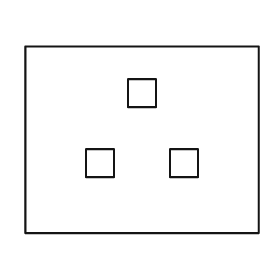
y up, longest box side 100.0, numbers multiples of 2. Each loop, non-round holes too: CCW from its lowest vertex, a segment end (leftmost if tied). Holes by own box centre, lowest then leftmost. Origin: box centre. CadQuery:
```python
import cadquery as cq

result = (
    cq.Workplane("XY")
    .moveTo(-50.0, -40.0)
    .lineTo(50.0, -40.0)
    .lineTo(50.0, 40.0)
    .lineTo(-50.0, 40.0)
    .close()
    .moveTo(-24.0, -16.0)
    .lineTo(-12.0, -16.0)
    .lineTo(-12.0, -4.0)
    .lineTo(-24.0, -4.0)
    .close()
    .moveTo(12.0, -16.0)
    .lineTo(24.0, -16.0)
    .lineTo(24.0, -4.0)
    .lineTo(12.0, -4.0)
    .close()
    .moveTo(-6.0, 14.0)
    .lineTo(6.0, 14.0)
    .lineTo(6.0, 26.0)
    .lineTo(-6.0, 26.0)
    .close()
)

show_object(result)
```